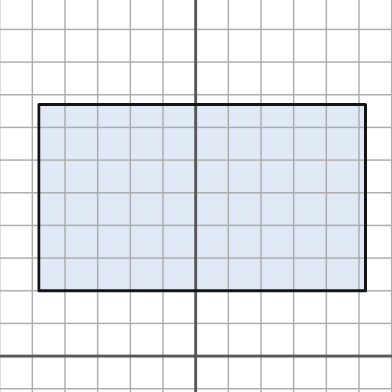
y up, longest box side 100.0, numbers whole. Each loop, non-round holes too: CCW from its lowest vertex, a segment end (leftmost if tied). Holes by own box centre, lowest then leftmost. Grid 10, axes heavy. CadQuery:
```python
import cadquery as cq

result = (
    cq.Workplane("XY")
    .moveTo(-48.0, 20.0)
    .lineTo(52.0, 20.0)
    .lineTo(52.0, 77.0)
    .lineTo(-48.0, 77.0)
    .close()
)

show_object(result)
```